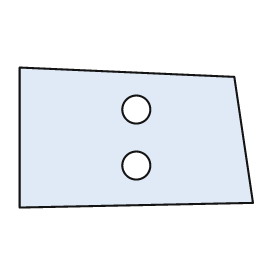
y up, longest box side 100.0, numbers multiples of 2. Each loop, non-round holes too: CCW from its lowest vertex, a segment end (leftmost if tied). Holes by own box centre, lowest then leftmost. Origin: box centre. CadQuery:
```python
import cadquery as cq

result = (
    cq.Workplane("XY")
    .moveTo(-50.0, -30.0)
    .lineTo(50.0, -28.0)
    .lineTo(42.0, 26.0)
    .lineTo(-50.0, 30.0)
    .close()
    .moveTo(0.0, -12.0)
    .circle(6.0)
    .moveTo(0.0, 12.0)
    .circle(6.0)
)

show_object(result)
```